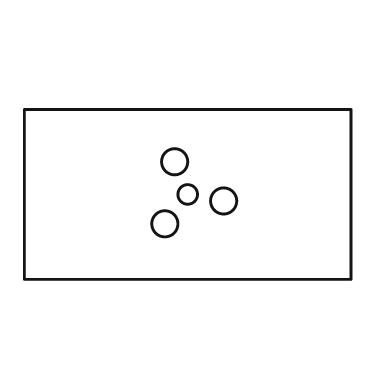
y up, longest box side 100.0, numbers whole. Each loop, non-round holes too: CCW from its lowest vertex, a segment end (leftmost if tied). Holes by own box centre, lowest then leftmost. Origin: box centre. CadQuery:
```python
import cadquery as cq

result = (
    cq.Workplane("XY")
    .moveTo(-50.0, -26.0)
    .lineTo(50.0, -26.0)
    .lineTo(50.0, 26.0)
    .lineTo(-50.0, 26.0)
    .close()
    .moveTo(-7.0, -9.0)
    .circle(4.0)
    .moveTo(11.0, -2.0)
    .circle(4.0)
    .moveTo(0.0, 0.0)
    .circle(3.0)
    .moveTo(-4.0, 10.0)
    .circle(4.0)
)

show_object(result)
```